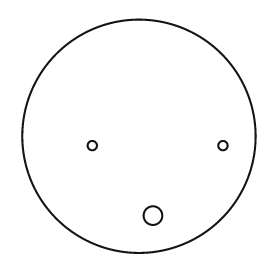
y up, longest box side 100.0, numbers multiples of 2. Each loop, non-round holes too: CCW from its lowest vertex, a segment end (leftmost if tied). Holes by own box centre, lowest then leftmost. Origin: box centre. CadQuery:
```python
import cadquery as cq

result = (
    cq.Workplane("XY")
    .moveTo(0.0, 0.0)
    .circle(50.0)
    .moveTo(6.0, -34.0)
    .circle(4.0)
    .moveTo(-20.0, -4.0)
    .circle(2.0)
    .moveTo(36.0, -4.0)
    .circle(2.0)
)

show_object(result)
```